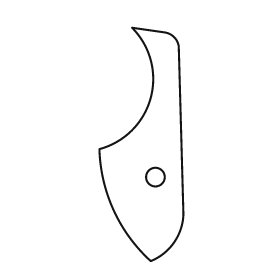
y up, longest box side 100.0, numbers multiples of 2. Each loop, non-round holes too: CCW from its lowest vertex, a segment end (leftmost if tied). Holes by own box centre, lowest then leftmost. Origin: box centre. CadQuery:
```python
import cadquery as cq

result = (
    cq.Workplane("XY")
    .moveTo(4.0, -50.0)
    .threePointArc((14.0, -42.0), (18.0, -30.0))
    .lineTo(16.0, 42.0)
    .threePointArc((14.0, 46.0), (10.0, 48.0))
    .lineTo(-4.0, 50.0)
    .threePointArc((4.0, 20.0), (-18.0, -2.0))
    .threePointArc((-12.0, -28.0), (4.0, -50.0))
    .close()
    .moveTo(6.0, -14.0)
    .circle(4.0)
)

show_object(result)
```